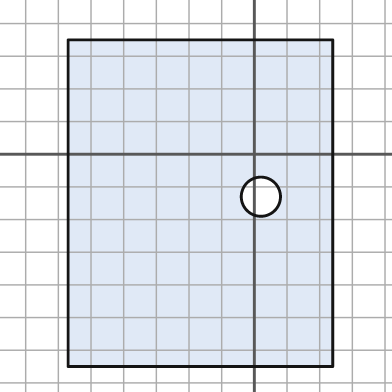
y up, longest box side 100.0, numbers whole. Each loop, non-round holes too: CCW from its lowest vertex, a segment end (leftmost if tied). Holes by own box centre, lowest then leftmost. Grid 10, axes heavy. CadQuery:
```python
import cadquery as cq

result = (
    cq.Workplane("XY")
    .moveTo(-57.0, -65.0)
    .lineTo(24.0, -65.0)
    .lineTo(24.0, 35.0)
    .lineTo(-57.0, 35.0)
    .close()
    .moveTo(2.0, -13.0)
    .circle(6.0)
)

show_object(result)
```